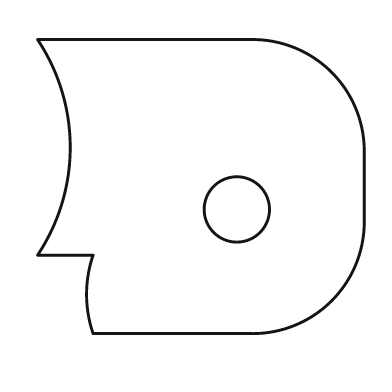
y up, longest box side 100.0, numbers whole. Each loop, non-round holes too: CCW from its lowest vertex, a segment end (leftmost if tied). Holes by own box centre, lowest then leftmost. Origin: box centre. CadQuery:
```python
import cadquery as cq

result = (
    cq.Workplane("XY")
    .moveTo(-33.0, -45.0)
    .lineTo(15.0, -45.0)
    .threePointArc((40.0, -35.0), (50.0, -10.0))
    .lineTo(50.0, 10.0)
    .threePointArc((40.0, 35.0), (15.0, 45.0))
    .lineTo(-50.0, 45.0)
    .threePointArc((-40.0, 12.0), (-50.0, -21.0))
    .lineTo(-33.0, -21.0)
    .threePointArc((-35.0, -33.0), (-33.0, -45.0))
    .close()
    .moveTo(11.0, -7.0)
    .circle(10.0)
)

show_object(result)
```